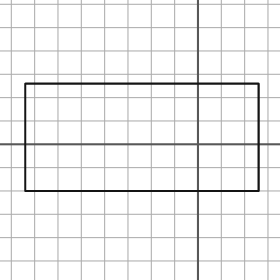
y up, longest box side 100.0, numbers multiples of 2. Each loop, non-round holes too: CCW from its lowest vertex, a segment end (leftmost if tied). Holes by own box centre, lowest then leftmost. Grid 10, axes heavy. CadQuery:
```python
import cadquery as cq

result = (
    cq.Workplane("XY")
    .moveTo(-74.0, -20.0)
    .lineTo(26.0, -20.0)
    .lineTo(26.0, 26.0)
    .lineTo(-74.0, 26.0)
    .close()
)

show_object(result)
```